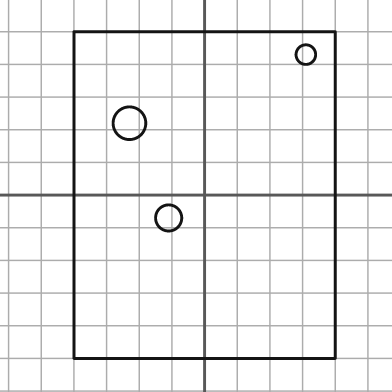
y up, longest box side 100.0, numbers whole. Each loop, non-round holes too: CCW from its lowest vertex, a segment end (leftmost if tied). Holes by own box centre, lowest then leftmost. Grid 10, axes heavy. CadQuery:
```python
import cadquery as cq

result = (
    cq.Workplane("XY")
    .moveTo(-40.0, -50.0)
    .lineTo(40.0, -50.0)
    .lineTo(40.0, 50.0)
    .lineTo(-40.0, 50.0)
    .close()
    .moveTo(-11.0, -7.0)
    .circle(4.0)
    .moveTo(-23.0, 22.0)
    .circle(5.0)
    .moveTo(31.0, 43.0)
    .circle(3.0)
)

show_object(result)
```